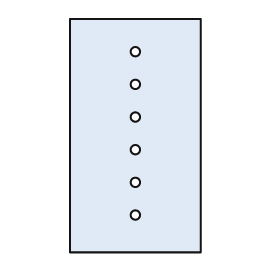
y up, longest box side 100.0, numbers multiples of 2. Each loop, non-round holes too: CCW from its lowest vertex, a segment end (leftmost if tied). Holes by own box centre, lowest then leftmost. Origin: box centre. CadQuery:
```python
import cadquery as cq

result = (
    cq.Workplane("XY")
    .moveTo(-28.0, -50.0)
    .lineTo(28.0, -50.0)
    .lineTo(28.0, 50.0)
    .lineTo(-28.0, 50.0)
    .close()
    .moveTo(0.0, -34.0)
    .circle(2.0)
    .moveTo(0.0, -20.0)
    .circle(2.0)
    .moveTo(0.0, -6.0)
    .circle(2.0)
    .moveTo(0.0, 8.0)
    .circle(2.0)
    .moveTo(0.0, 22.0)
    .circle(2.0)
    .moveTo(0.0, 36.0)
    .circle(2.0)
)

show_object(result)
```